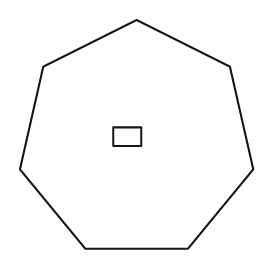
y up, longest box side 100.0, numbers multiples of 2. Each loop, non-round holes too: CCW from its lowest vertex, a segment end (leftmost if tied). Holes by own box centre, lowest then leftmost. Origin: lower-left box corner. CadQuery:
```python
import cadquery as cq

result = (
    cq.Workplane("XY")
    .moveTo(28.0, 0.0)
    .lineTo(72.0, 0.0)
    .lineTo(100.0, 34.0)
    .lineTo(90.0, 78.0)
    .lineTo(50.0, 98.0)
    .lineTo(10.0, 78.0)
    .lineTo(0.0, 34.0)
    .close()
    .moveTo(40.0, 44.0)
    .lineTo(52.0, 44.0)
    .lineTo(52.0, 52.0)
    .lineTo(40.0, 52.0)
    .close()
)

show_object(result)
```